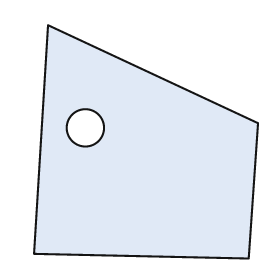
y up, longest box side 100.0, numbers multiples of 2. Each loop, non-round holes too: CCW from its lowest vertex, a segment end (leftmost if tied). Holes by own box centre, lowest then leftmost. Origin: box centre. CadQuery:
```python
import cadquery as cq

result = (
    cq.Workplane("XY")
    .moveTo(44.0, -50.0)
    .lineTo(48.0, 8.0)
    .lineTo(-42.0, 50.0)
    .lineTo(-48.0, -48.0)
    .close()
    .moveTo(-26.0, 6.0)
    .circle(8.0)
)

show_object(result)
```